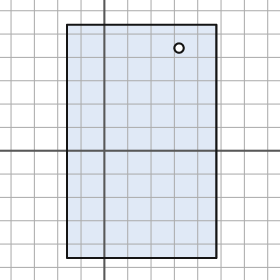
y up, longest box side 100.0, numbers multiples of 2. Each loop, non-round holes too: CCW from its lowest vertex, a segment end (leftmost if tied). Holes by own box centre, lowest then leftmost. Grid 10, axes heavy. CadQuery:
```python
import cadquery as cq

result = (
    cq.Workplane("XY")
    .moveTo(-16.0, -46.0)
    .lineTo(48.0, -46.0)
    .lineTo(48.0, 54.0)
    .lineTo(-16.0, 54.0)
    .close()
    .moveTo(32.0, 44.0)
    .circle(2.0)
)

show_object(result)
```